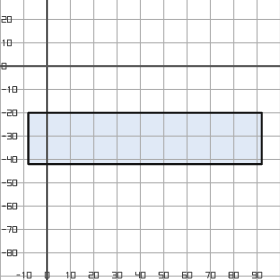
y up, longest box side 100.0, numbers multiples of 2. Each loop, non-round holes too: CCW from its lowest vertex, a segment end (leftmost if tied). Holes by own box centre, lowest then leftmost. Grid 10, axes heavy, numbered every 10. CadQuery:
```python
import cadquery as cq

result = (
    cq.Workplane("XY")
    .moveTo(-8.0, -42.0)
    .lineTo(92.0, -42.0)
    .lineTo(92.0, -20.0)
    .lineTo(-8.0, -20.0)
    .close()
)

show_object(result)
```